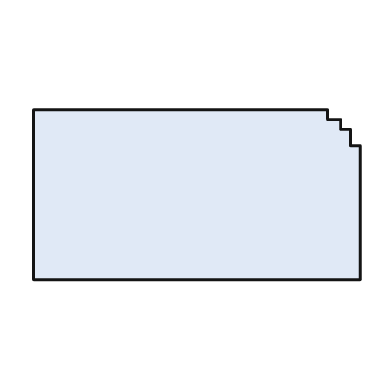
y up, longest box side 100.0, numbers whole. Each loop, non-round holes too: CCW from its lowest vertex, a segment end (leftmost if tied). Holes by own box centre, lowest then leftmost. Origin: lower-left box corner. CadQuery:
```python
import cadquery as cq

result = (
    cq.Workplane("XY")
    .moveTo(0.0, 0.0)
    .lineTo(100.0, 0.0)
    .lineTo(100.0, 41.0)
    .lineTo(97.0, 41.0)
    .lineTo(97.0, 46.0)
    .lineTo(94.0, 46.0)
    .lineTo(94.0, 49.0)
    .lineTo(90.0, 49.0)
    .lineTo(90.0, 52.0)
    .lineTo(0.0, 52.0)
    .close()
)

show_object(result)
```